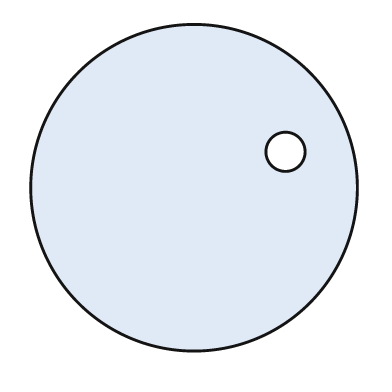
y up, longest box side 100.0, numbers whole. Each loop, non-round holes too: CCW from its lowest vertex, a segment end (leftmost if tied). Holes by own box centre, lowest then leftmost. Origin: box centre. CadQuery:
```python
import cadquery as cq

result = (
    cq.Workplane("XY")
    .moveTo(0.0, 0.0)
    .circle(50.0)
    .moveTo(28.0, 11.0)
    .circle(6.0)
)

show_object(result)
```